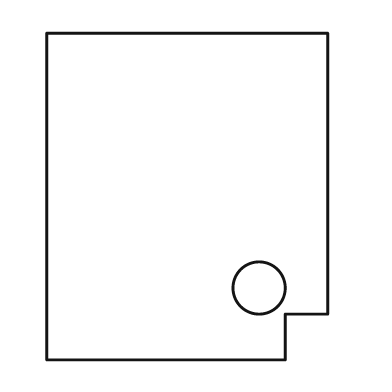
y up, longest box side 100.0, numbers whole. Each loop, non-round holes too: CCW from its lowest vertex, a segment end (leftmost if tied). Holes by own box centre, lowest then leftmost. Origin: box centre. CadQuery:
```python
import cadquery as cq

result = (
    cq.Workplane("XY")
    .moveTo(-43.0, -50.0)
    .lineTo(30.0, -50.0)
    .lineTo(30.0, -36.0)
    .lineTo(43.0, -36.0)
    .lineTo(43.0, 50.0)
    .lineTo(-43.0, 50.0)
    .close()
    .moveTo(22.0, -28.0)
    .circle(8.0)
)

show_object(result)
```